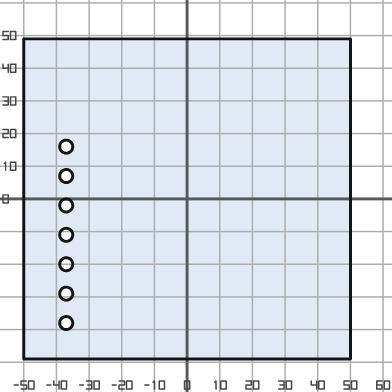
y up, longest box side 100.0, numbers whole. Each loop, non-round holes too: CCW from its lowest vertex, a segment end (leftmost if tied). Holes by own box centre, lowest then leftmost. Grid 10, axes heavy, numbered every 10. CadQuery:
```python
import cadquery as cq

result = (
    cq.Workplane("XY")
    .moveTo(-50.0, -49.0)
    .lineTo(50.0, -49.0)
    .lineTo(50.0, 49.0)
    .lineTo(-50.0, 49.0)
    .close()
    .moveTo(-37.0, -38.0)
    .circle(2.0)
    .moveTo(-37.0, -29.0)
    .circle(2.0)
    .moveTo(-37.0, -20.0)
    .circle(2.0)
    .moveTo(-37.0, -11.0)
    .circle(2.0)
    .moveTo(-37.0, -2.0)
    .circle(2.0)
    .moveTo(-37.0, 7.0)
    .circle(2.0)
    .moveTo(-37.0, 16.0)
    .circle(2.0)
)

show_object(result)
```